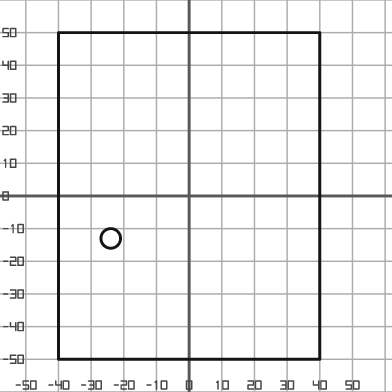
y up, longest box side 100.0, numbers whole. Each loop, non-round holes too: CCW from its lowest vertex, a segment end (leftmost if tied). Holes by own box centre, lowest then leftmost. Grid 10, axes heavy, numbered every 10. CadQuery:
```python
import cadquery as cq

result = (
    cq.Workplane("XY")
    .moveTo(-40.0, -50.0)
    .lineTo(40.0, -50.0)
    .lineTo(40.0, 50.0)
    .lineTo(-40.0, 50.0)
    .close()
    .moveTo(-24.0, -13.0)
    .circle(3.0)
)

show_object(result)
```